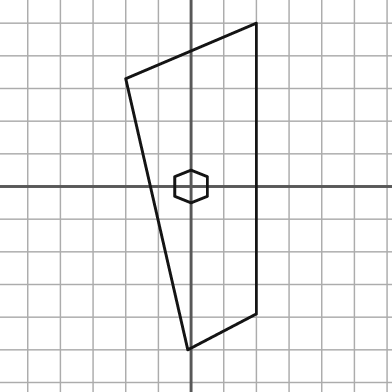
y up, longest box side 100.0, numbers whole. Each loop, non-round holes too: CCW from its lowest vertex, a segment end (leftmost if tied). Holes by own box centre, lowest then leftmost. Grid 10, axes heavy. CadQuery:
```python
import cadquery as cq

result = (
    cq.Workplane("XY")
    .moveTo(-1.0, -50.0)
    .lineTo(20.0, -39.0)
    .lineTo(20.0, 50.0)
    .lineTo(-20.0, 33.0)
    .close()
    .moveTo(0.0, -5.0)
    .lineTo(5.0, -3.0)
    .lineTo(5.0, 3.0)
    .lineTo(0.0, 5.0)
    .lineTo(-5.0, 3.0)
    .lineTo(-5.0, -3.0)
    .close()
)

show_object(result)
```